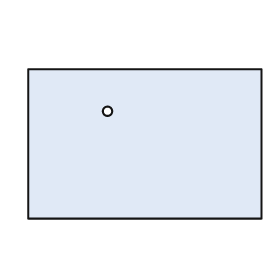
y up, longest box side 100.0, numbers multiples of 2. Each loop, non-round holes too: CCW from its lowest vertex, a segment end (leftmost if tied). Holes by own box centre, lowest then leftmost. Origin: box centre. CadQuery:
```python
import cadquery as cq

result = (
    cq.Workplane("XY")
    .moveTo(-50.0, -32.0)
    .lineTo(50.0, -32.0)
    .lineTo(50.0, 32.0)
    .lineTo(-50.0, 32.0)
    .close()
    .moveTo(-16.0, 14.0)
    .circle(2.0)
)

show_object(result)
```